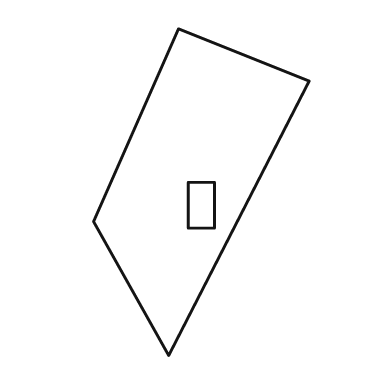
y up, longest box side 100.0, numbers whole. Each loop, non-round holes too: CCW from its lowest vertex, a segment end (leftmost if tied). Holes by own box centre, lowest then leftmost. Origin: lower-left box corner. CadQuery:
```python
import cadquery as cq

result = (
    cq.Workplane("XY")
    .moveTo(23.0, 0.0)
    .lineTo(66.0, 84.0)
    .lineTo(26.0, 100.0)
    .lineTo(0.0, 41.0)
    .close()
    .moveTo(29.0, 39.0)
    .lineTo(37.0, 39.0)
    .lineTo(37.0, 53.0)
    .lineTo(29.0, 53.0)
    .close()
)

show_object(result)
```